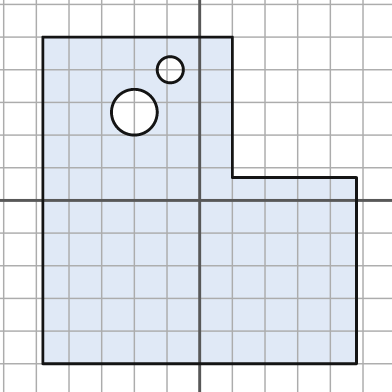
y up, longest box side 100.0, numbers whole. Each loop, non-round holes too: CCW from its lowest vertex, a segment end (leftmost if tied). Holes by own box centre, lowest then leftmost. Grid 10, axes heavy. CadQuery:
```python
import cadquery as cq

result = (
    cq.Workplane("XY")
    .moveTo(-48.0, -50.0)
    .lineTo(48.0, -50.0)
    .lineTo(48.0, 7.0)
    .lineTo(10.0, 7.0)
    .lineTo(10.0, 50.0)
    .lineTo(-48.0, 50.0)
    .close()
    .moveTo(-20.0, 27.0)
    .circle(7.0)
    .moveTo(-9.0, 40.0)
    .circle(4.0)
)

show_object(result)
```